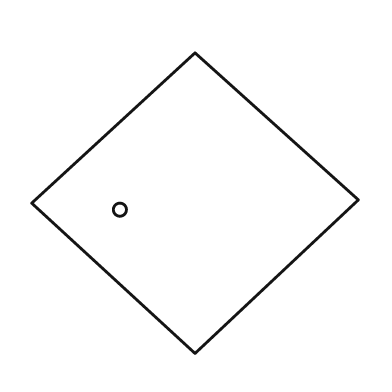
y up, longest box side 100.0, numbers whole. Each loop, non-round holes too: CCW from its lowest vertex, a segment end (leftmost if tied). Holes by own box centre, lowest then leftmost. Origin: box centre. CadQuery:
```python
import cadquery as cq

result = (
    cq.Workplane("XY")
    .moveTo(0.0, -46.0)
    .lineTo(50.0, 1.0)
    .lineTo(0.0, 46.0)
    .lineTo(-50.0, 0.0)
    .close()
    .moveTo(-23.0, -2.0)
    .circle(2.0)
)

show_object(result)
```